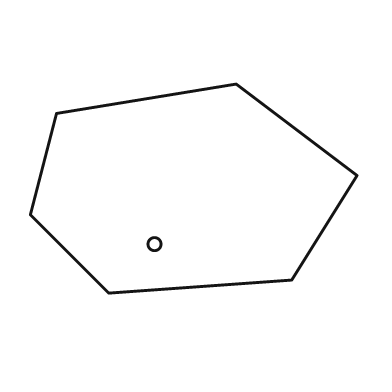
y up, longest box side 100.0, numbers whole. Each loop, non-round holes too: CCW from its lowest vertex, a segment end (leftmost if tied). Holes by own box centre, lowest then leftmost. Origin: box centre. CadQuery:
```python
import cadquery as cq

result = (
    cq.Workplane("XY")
    .moveTo(-26.0, -32.0)
    .lineTo(30.0, -28.0)
    .lineTo(50.0, 4.0)
    .lineTo(13.0, 32.0)
    .lineTo(-42.0, 23.0)
    .lineTo(-50.0, -8.0)
    .close()
    .moveTo(-12.0, -17.0)
    .circle(2.0)
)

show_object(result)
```